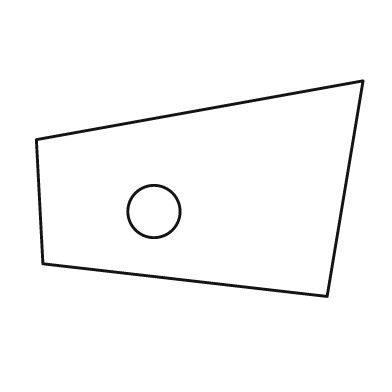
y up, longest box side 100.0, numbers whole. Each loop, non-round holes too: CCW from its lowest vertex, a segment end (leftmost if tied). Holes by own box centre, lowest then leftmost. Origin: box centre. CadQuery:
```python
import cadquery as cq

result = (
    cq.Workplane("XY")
    .moveTo(39.0, -33.0)
    .lineTo(50.0, 33.0)
    .lineTo(-50.0, 15.0)
    .lineTo(-48.0, -23.0)
    .close()
    .moveTo(-14.0, -7.0)
    .circle(8.0)
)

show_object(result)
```